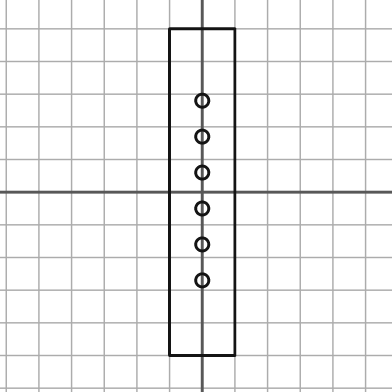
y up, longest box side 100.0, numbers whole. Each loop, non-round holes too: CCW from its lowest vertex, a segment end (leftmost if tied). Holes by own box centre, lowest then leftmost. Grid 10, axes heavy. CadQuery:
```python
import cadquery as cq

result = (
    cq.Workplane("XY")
    .moveTo(-10.0, -50.0)
    .lineTo(10.0, -50.0)
    .lineTo(10.0, 50.0)
    .lineTo(-10.0, 50.0)
    .close()
    .moveTo(0.0, -27.0)
    .circle(2.0)
    .moveTo(0.0, -16.0)
    .circle(2.0)
    .moveTo(0.0, -5.0)
    .circle(2.0)
    .moveTo(0.0, 6.0)
    .circle(2.0)
    .moveTo(0.0, 17.0)
    .circle(2.0)
    .moveTo(0.0, 28.0)
    .circle(2.0)
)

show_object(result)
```